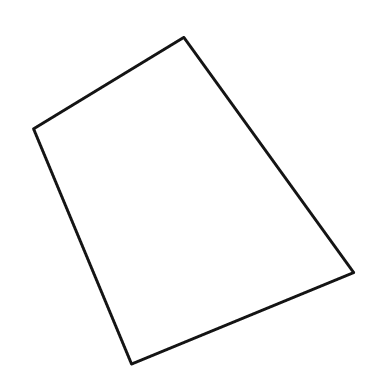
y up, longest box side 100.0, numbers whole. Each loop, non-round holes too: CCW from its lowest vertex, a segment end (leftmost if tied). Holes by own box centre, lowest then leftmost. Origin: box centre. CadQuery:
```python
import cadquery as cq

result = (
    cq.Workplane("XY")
    .moveTo(-19.0, -50.0)
    .lineTo(49.0, -22.0)
    .lineTo(-3.0, 50.0)
    .lineTo(-49.0, 22.0)
    .close()
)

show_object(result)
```